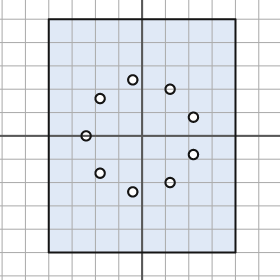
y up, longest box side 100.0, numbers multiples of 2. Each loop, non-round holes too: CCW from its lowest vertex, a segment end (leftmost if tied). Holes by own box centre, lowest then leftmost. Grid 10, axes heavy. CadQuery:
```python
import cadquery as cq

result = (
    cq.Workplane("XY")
    .moveTo(-40.0, -50.0)
    .lineTo(40.0, -50.0)
    .lineTo(40.0, 50.0)
    .lineTo(-40.0, 50.0)
    .close()
    .moveTo(-4.0, -24.0)
    .circle(2.0)
    .moveTo(12.0, -20.0)
    .circle(2.0)
    .moveTo(-18.0, -16.0)
    .circle(2.0)
    .moveTo(22.0, -8.0)
    .circle(2.0)
    .moveTo(-24.0, 0.0)
    .circle(2.0)
    .moveTo(22.0, 8.0)
    .circle(2.0)
    .moveTo(-18.0, 16.0)
    .circle(2.0)
    .moveTo(12.0, 20.0)
    .circle(2.0)
    .moveTo(-4.0, 24.0)
    .circle(2.0)
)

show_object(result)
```